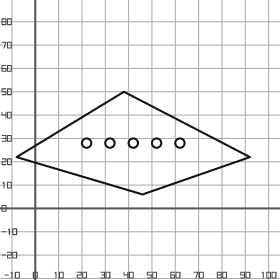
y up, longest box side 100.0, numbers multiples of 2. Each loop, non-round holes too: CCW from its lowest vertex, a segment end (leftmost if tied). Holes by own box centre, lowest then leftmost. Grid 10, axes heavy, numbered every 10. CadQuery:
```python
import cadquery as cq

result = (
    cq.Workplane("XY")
    .moveTo(46.0, 6.0)
    .lineTo(92.0, 22.0)
    .lineTo(38.0, 50.0)
    .lineTo(-8.0, 22.0)
    .close()
    .moveTo(22.0, 28.0)
    .circle(2.0)
    .moveTo(32.0, 28.0)
    .circle(2.0)
    .moveTo(42.0, 28.0)
    .circle(2.0)
    .moveTo(52.0, 28.0)
    .circle(2.0)
    .moveTo(62.0, 28.0)
    .circle(2.0)
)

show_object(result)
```